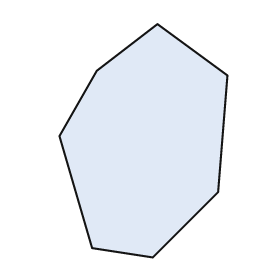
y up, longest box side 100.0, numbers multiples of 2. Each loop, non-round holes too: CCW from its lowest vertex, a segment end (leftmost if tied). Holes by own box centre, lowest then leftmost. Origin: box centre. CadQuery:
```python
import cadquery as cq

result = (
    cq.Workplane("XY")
    .moveTo(4.0, -50.0)
    .lineTo(32.0, -22.0)
    .lineTo(36.0, 28.0)
    .lineTo(6.0, 50.0)
    .lineTo(-20.0, 30.0)
    .lineTo(-36.0, 2.0)
    .lineTo(-22.0, -46.0)
    .close()
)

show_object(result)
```